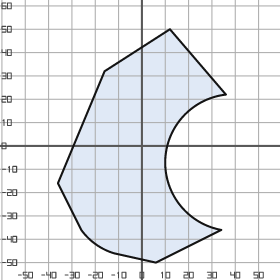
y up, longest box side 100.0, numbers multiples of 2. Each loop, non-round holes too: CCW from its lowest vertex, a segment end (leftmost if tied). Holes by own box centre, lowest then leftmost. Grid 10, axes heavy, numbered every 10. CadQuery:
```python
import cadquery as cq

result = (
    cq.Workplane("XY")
    .moveTo(6.0, -50.0)
    .lineTo(34.0, -36.0)
    .threePointArc((10.0, -6.0), (36.0, 22.0))
    .lineTo(12.0, 50.0)
    .lineTo(-16.0, 32.0)
    .lineTo(-36.0, -16.0)
    .lineTo(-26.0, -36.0)
    .threePointArc((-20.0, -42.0), (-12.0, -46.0))
    .close()
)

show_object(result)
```